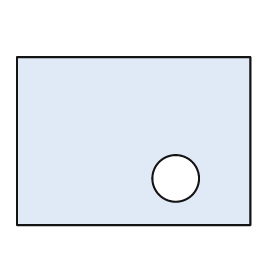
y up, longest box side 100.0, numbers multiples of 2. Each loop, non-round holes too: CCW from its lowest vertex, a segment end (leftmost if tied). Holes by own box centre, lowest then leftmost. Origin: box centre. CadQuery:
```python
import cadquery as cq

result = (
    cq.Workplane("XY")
    .moveTo(-50.0, -36.0)
    .lineTo(50.0, -36.0)
    .lineTo(50.0, 36.0)
    .lineTo(-50.0, 36.0)
    .close()
    .moveTo(18.0, -16.0)
    .circle(10.0)
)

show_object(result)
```